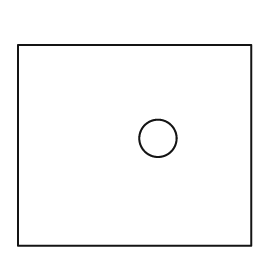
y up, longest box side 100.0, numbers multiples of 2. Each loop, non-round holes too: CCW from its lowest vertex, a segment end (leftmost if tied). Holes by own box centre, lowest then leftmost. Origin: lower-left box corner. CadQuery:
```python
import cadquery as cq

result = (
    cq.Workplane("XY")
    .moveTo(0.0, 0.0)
    .lineTo(100.0, 0.0)
    .lineTo(100.0, 86.0)
    .lineTo(0.0, 86.0)
    .close()
    .moveTo(60.0, 46.0)
    .circle(8.0)
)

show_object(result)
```